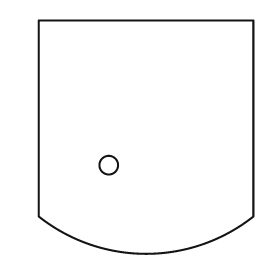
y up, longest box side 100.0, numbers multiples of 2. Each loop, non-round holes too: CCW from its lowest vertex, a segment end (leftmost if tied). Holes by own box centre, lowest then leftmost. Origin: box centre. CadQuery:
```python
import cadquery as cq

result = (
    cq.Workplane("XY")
    .moveTo(-46.0, -34.0)
    .threePointArc((0.0, -50.0), (46.0, -34.0))
    .lineTo(46.0, 50.0)
    .lineTo(-46.0, 50.0)
    .close()
    .moveTo(-16.0, -12.0)
    .circle(4.0)
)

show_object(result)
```